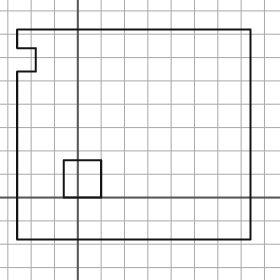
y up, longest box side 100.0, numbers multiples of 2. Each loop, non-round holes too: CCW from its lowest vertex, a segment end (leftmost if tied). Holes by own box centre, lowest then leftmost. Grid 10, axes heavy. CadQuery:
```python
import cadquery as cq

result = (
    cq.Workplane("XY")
    .moveTo(-26.0, -18.0)
    .lineTo(74.0, -18.0)
    .lineTo(74.0, 72.0)
    .lineTo(-26.0, 72.0)
    .lineTo(-26.0, 64.0)
    .lineTo(-18.0, 64.0)
    .lineTo(-18.0, 54.0)
    .lineTo(-26.0, 54.0)
    .close()
    .moveTo(-6.0, 0.0)
    .lineTo(10.0, 0.0)
    .lineTo(10.0, 16.0)
    .lineTo(-6.0, 16.0)
    .close()
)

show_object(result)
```